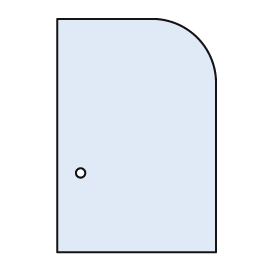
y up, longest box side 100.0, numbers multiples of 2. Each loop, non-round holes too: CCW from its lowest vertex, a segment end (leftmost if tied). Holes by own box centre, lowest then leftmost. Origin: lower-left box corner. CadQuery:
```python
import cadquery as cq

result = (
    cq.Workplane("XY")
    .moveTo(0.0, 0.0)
    .lineTo(68.0, 0.0)
    .lineTo(68.0, 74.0)
    .threePointArc((60.0, 92.0), (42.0, 100.0))
    .lineTo(0.0, 100.0)
    .close()
    .moveTo(10.0, 34.0)
    .circle(2.0)
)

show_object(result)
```